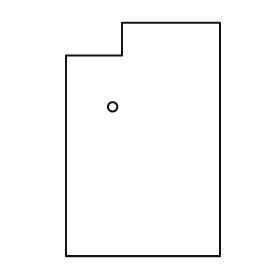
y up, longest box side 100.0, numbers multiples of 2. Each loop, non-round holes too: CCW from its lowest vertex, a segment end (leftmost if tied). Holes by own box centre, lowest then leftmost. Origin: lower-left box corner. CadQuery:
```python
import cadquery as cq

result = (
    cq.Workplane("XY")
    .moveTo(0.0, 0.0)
    .lineTo(66.0, 0.0)
    .lineTo(66.0, 100.0)
    .lineTo(24.0, 100.0)
    .lineTo(24.0, 86.0)
    .lineTo(0.0, 86.0)
    .close()
    .moveTo(20.0, 64.0)
    .circle(2.0)
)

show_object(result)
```